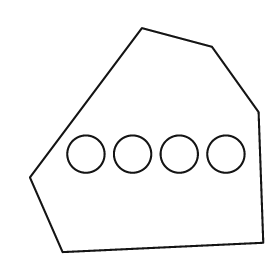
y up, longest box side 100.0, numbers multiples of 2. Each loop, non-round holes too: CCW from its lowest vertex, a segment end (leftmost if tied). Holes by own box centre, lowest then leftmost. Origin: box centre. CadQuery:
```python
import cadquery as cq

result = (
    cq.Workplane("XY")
    .moveTo(-36.0, -48.0)
    .lineTo(50.0, -44.0)
    .lineTo(48.0, 12.0)
    .lineTo(28.0, 40.0)
    .lineTo(-2.0, 48.0)
    .lineTo(-50.0, -16.0)
    .close()
    .moveTo(-26.0, -6.0)
    .circle(8.0)
    .moveTo(-6.0, -6.0)
    .circle(8.0)
    .moveTo(14.0, -6.0)
    .circle(8.0)
    .moveTo(34.0, -6.0)
    .circle(8.0)
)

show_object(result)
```